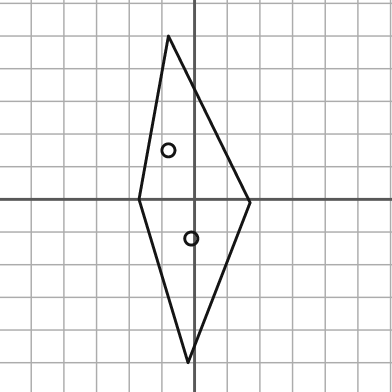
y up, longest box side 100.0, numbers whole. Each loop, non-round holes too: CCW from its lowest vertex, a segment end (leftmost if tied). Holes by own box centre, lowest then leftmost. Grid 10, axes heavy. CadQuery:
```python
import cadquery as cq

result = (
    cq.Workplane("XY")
    .moveTo(-2.0, -50.0)
    .lineTo(17.0, -1.0)
    .lineTo(-8.0, 50.0)
    .lineTo(-17.0, 0.0)
    .close()
    .moveTo(-1.0, -12.0)
    .circle(2.0)
    .moveTo(-8.0, 15.0)
    .circle(2.0)
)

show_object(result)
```